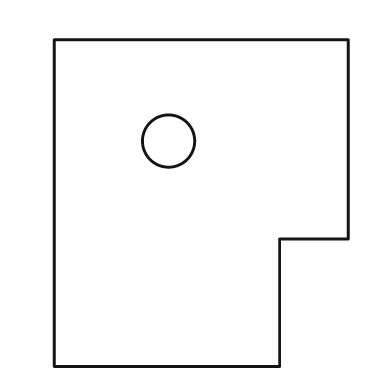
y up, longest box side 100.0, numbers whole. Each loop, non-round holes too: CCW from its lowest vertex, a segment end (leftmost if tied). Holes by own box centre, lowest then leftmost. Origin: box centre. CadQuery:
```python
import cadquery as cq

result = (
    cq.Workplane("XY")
    .moveTo(-45.0, -50.0)
    .lineTo(24.0, -50.0)
    .lineTo(24.0, -11.0)
    .lineTo(45.0, -11.0)
    .lineTo(45.0, 50.0)
    .lineTo(-45.0, 50.0)
    .close()
    .moveTo(-10.0, 19.0)
    .circle(8.0)
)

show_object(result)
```